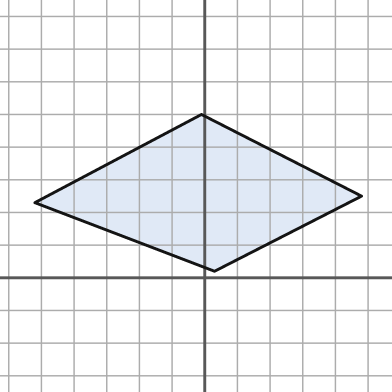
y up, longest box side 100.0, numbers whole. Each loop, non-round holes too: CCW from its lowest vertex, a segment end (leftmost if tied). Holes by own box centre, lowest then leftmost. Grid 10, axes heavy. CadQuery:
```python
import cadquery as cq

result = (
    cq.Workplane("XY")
    .moveTo(3.0, 2.0)
    .lineTo(48.0, 25.0)
    .lineTo(-1.0, 50.0)
    .lineTo(-52.0, 23.0)
    .close()
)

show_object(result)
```